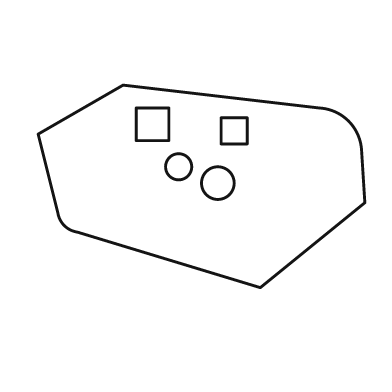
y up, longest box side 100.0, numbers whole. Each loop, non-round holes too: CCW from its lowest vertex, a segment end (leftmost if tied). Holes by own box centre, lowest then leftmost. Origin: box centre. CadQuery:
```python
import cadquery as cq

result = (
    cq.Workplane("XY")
    .moveTo(18.0, -31.0)
    .lineTo(50.0, -5.0)
    .lineTo(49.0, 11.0)
    .threePointArc((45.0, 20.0), (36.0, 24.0))
    .lineTo(-24.0, 31.0)
    .lineTo(-50.0, 16.0)
    .lineTo(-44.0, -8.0)
    .threePointArc((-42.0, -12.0), (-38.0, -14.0))
    .close()
    .moveTo(5.0, 1.0)
    .circle(5.0)
    .moveTo(-7.0, 6.0)
    .circle(4.0)
    .moveTo(6.0, 13.0)
    .lineTo(14.0, 13.0)
    .lineTo(14.0, 21.0)
    .lineTo(6.0, 21.0)
    .close()
    .moveTo(-20.0, 14.0)
    .lineTo(-10.0, 14.0)
    .lineTo(-10.0, 24.0)
    .lineTo(-20.0, 24.0)
    .close()
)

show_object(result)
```